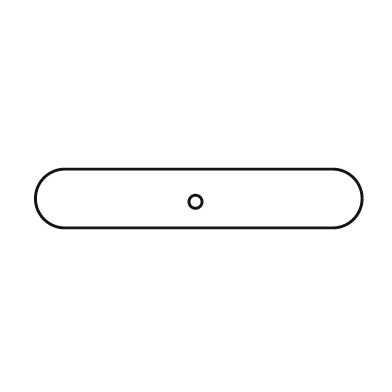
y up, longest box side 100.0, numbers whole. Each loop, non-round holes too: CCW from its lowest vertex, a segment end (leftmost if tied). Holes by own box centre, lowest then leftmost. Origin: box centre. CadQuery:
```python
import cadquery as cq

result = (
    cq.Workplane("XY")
    .moveTo(-41.0, -9.0)
    .lineTo(41.0, -9.0)
    .threePointArc((50.0, 0.0), (41.0, 9.0))
    .lineTo(-41.0, 9.0)
    .threePointArc((-50.0, 0.0), (-41.0, -9.0))
    .close()
    .moveTo(-1.0, -1.0)
    .circle(2.0)
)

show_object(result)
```